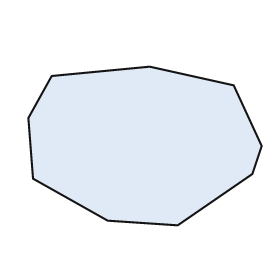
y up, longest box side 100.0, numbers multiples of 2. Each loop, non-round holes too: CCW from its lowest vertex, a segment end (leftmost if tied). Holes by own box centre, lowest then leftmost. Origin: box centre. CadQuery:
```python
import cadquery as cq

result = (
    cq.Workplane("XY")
    .moveTo(14.0, -34.0)
    .lineTo(46.0, -12.0)
    .lineTo(50.0, 0.0)
    .lineTo(38.0, 26.0)
    .lineTo(2.0, 34.0)
    .lineTo(-40.0, 30.0)
    .lineTo(-50.0, 12.0)
    .lineTo(-48.0, -14.0)
    .lineTo(-16.0, -32.0)
    .close()
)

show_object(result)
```